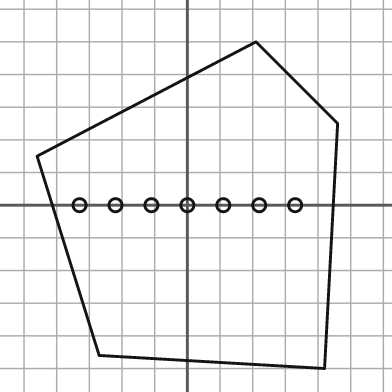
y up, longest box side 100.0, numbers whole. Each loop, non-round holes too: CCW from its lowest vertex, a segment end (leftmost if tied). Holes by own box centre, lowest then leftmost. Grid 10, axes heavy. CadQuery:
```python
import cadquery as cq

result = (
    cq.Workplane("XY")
    .moveTo(42.0, -50.0)
    .lineTo(46.0, 25.0)
    .lineTo(21.0, 50.0)
    .lineTo(-46.0, 15.0)
    .lineTo(-27.0, -46.0)
    .close()
    .moveTo(-33.0, 0.0)
    .circle(2.0)
    .moveTo(-22.0, 0.0)
    .circle(2.0)
    .moveTo(-11.0, 0.0)
    .circle(2.0)
    .moveTo(0.0, 0.0)
    .circle(2.0)
    .moveTo(11.0, 0.0)
    .circle(2.0)
    .moveTo(22.0, 0.0)
    .circle(2.0)
    .moveTo(33.0, 0.0)
    .circle(2.0)
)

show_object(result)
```